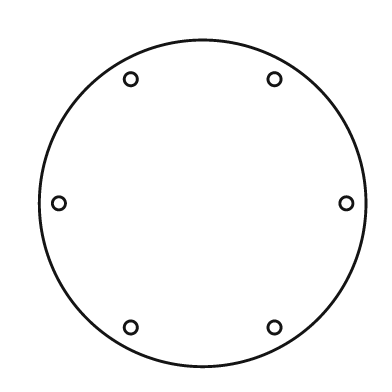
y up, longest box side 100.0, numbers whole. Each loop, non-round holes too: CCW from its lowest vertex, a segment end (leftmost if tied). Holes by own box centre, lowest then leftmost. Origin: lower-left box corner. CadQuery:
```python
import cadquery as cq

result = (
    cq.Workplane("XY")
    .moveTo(50.0, 50.0)
    .circle(50.0)
    .moveTo(28.0, 12.0)
    .circle(2.0)
    .moveTo(72.0, 12.0)
    .circle(2.0)
    .moveTo(6.0, 50.0)
    .circle(2.0)
    .moveTo(94.0, 50.0)
    .circle(2.0)
    .moveTo(28.0, 88.0)
    .circle(2.0)
    .moveTo(72.0, 88.0)
    .circle(2.0)
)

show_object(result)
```